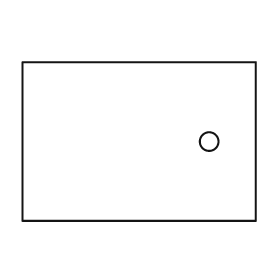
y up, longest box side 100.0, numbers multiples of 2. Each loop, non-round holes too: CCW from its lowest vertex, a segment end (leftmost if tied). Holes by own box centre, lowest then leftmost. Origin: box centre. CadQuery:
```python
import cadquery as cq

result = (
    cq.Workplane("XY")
    .moveTo(-50.0, -34.0)
    .lineTo(50.0, -34.0)
    .lineTo(50.0, 34.0)
    .lineTo(-50.0, 34.0)
    .close()
    .moveTo(30.0, 0.0)
    .circle(4.0)
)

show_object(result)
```